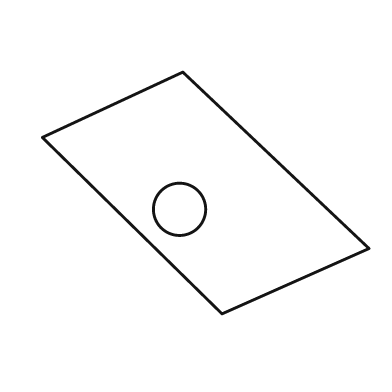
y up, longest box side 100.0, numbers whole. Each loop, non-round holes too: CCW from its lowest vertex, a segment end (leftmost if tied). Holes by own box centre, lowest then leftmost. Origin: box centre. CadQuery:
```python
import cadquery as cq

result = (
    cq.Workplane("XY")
    .moveTo(5.0, -37.0)
    .lineTo(50.0, -17.0)
    .lineTo(-7.0, 37.0)
    .lineTo(-50.0, 17.0)
    .close()
    .moveTo(-8.0, -5.0)
    .circle(8.0)
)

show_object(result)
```